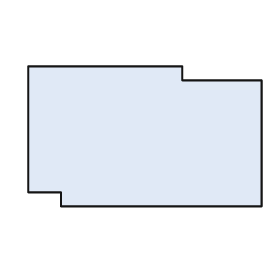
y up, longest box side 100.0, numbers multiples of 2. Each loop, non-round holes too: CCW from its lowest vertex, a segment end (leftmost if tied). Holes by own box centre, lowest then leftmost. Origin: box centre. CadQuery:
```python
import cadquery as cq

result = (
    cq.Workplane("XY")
    .moveTo(-36.0, -30.0)
    .lineTo(50.0, -30.0)
    .lineTo(50.0, 24.0)
    .lineTo(16.0, 24.0)
    .lineTo(16.0, 30.0)
    .lineTo(-50.0, 30.0)
    .lineTo(-50.0, -24.0)
    .lineTo(-36.0, -24.0)
    .close()
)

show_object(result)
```